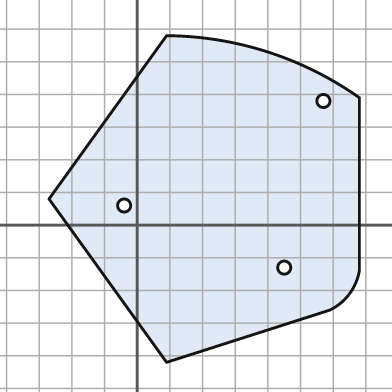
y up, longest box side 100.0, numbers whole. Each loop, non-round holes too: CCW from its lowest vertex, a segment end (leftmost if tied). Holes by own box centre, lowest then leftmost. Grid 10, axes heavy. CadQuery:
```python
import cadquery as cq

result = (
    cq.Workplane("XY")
    .moveTo(9.0, -42.0)
    .lineTo(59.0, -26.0)
    .threePointArc((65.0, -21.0), (68.0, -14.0))
    .lineTo(68.0, 39.0)
    .threePointArc((40.0, 53.0), (9.0, 58.0))
    .lineTo(-27.0, 8.0)
    .close()
    .moveTo(45.0, -13.0)
    .circle(2.0)
    .moveTo(-4.0, 6.0)
    .circle(2.0)
    .moveTo(57.0, 38.0)
    .circle(2.0)
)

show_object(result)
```